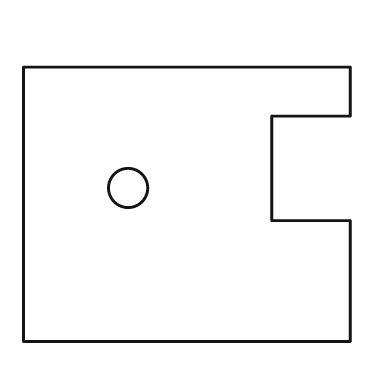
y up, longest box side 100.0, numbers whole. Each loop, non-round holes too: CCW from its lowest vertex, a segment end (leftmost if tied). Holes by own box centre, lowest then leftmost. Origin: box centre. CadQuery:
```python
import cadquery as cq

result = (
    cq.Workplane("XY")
    .moveTo(-50.0, -42.0)
    .lineTo(50.0, -42.0)
    .lineTo(50.0, -5.0)
    .lineTo(26.0, -5.0)
    .lineTo(26.0, 27.0)
    .lineTo(50.0, 27.0)
    .lineTo(50.0, 42.0)
    .lineTo(-50.0, 42.0)
    .close()
    .moveTo(-18.0, 5.0)
    .circle(6.0)
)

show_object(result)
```